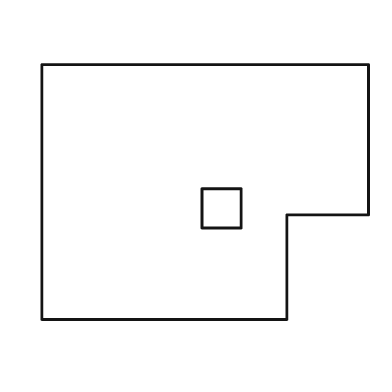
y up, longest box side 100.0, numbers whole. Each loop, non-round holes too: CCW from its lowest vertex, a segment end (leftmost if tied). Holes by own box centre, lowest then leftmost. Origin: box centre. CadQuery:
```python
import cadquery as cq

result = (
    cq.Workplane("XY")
    .moveTo(-50.0, -39.0)
    .lineTo(25.0, -39.0)
    .lineTo(25.0, -7.0)
    .lineTo(50.0, -7.0)
    .lineTo(50.0, 39.0)
    .lineTo(-50.0, 39.0)
    .close()
    .moveTo(-1.0, -11.0)
    .lineTo(11.0, -11.0)
    .lineTo(11.0, 1.0)
    .lineTo(-1.0, 1.0)
    .close()
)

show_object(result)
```